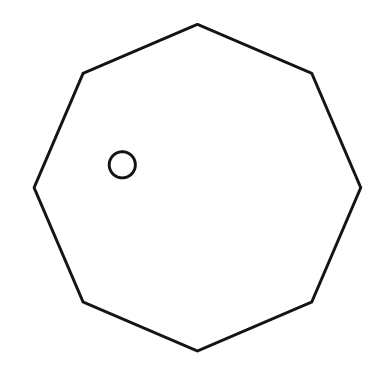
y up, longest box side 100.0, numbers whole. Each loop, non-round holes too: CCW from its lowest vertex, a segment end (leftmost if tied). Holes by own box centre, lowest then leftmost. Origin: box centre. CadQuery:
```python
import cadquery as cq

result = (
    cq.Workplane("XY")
    .moveTo(0.0, -50.0)
    .lineTo(35.0, -35.0)
    .lineTo(50.0, 0.0)
    .lineTo(35.0, 35.0)
    .lineTo(0.0, 50.0)
    .lineTo(-35.0, 35.0)
    .lineTo(-50.0, 0.0)
    .lineTo(-35.0, -35.0)
    .close()
    .moveTo(-23.0, 7.0)
    .circle(4.0)
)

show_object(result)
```